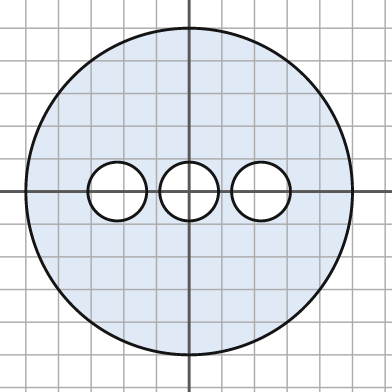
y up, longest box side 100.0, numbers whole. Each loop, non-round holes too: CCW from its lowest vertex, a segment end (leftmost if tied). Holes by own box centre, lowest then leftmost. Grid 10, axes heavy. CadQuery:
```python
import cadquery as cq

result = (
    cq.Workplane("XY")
    .moveTo(0.0, 0.0)
    .circle(50.0)
    .moveTo(-22.0, 0.0)
    .circle(9.0)
    .moveTo(0.0, 0.0)
    .circle(9.0)
    .moveTo(22.0, 0.0)
    .circle(9.0)
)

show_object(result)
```